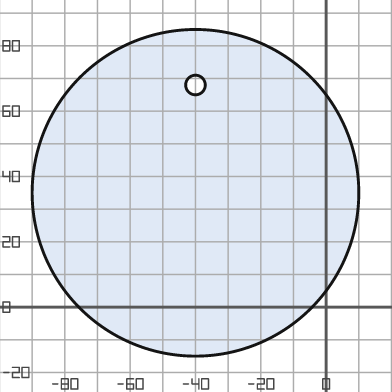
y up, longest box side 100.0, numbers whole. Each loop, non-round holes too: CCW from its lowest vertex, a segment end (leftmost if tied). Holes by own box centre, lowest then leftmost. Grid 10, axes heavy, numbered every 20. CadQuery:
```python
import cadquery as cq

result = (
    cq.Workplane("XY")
    .moveTo(-40.0, 35.0)
    .circle(50.0)
    .moveTo(-40.0, 68.0)
    .circle(3.0)
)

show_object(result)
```